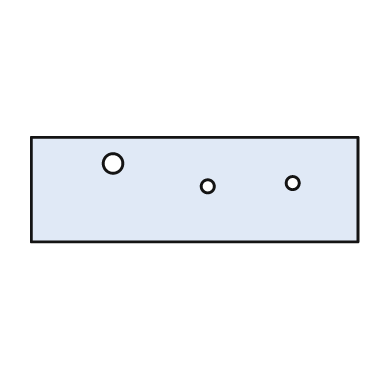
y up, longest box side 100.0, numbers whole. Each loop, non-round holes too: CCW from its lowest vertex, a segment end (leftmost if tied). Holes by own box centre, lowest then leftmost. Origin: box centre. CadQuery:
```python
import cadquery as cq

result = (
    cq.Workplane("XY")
    .moveTo(-50.0, -16.0)
    .lineTo(50.0, -16.0)
    .lineTo(50.0, 16.0)
    .lineTo(-50.0, 16.0)
    .close()
    .moveTo(4.0, 1.0)
    .circle(2.0)
    .moveTo(30.0, 2.0)
    .circle(2.0)
    .moveTo(-25.0, 8.0)
    .circle(3.0)
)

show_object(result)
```